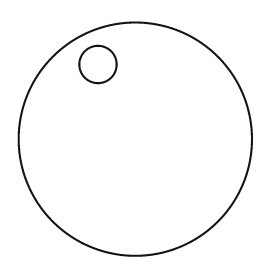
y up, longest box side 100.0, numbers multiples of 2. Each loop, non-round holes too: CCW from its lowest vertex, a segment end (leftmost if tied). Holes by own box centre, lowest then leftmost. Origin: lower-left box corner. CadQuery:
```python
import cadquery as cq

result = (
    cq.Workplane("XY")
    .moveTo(50.0, 50.0)
    .circle(50.0)
    .moveTo(34.0, 82.0)
    .circle(8.0)
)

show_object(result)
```